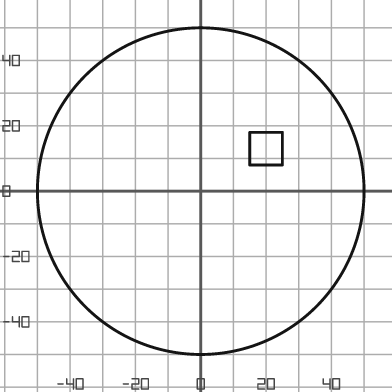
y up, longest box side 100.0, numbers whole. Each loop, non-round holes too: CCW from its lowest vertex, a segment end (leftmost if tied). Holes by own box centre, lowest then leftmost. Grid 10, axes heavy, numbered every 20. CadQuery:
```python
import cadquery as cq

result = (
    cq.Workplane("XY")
    .moveTo(0.0, 0.0)
    .circle(50.0)
    .moveTo(15.0, 8.0)
    .lineTo(25.0, 8.0)
    .lineTo(25.0, 18.0)
    .lineTo(15.0, 18.0)
    .close()
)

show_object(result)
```